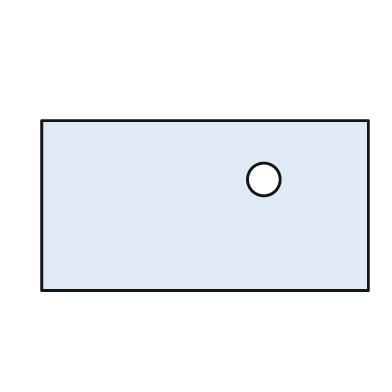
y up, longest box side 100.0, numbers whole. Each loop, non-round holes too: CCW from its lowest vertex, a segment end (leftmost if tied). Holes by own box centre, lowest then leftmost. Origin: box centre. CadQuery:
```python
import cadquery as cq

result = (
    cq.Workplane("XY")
    .moveTo(-50.0, -26.0)
    .lineTo(50.0, -26.0)
    .lineTo(50.0, 26.0)
    .lineTo(-50.0, 26.0)
    .close()
    .moveTo(18.0, 8.0)
    .circle(5.0)
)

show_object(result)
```